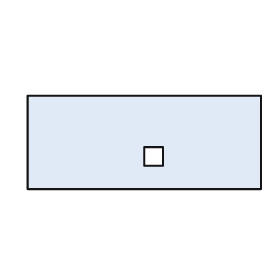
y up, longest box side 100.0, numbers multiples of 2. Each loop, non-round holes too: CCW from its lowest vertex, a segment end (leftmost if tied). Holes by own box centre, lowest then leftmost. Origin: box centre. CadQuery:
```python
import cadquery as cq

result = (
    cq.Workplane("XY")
    .moveTo(-50.0, -20.0)
    .lineTo(50.0, -20.0)
    .lineTo(50.0, 20.0)
    .lineTo(-50.0, 20.0)
    .close()
    .moveTo(0.0, -10.0)
    .lineTo(8.0, -10.0)
    .lineTo(8.0, -2.0)
    .lineTo(0.0, -2.0)
    .close()
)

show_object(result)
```